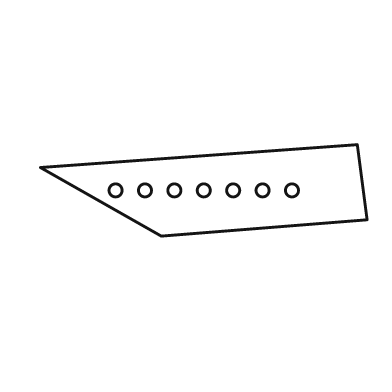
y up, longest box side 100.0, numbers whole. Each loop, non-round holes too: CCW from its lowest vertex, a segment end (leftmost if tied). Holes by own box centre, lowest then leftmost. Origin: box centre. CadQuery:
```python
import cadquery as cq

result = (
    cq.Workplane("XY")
    .moveTo(-13.0, -14.0)
    .lineTo(50.0, -9.0)
    .lineTo(47.0, 14.0)
    .lineTo(-50.0, 7.0)
    .close()
    .moveTo(-27.0, 0.0)
    .circle(2.0)
    .moveTo(-18.0, 0.0)
    .circle(2.0)
    .moveTo(-9.0, 0.0)
    .circle(2.0)
    .moveTo(0.0, 0.0)
    .circle(2.0)
    .moveTo(9.0, 0.0)
    .circle(2.0)
    .moveTo(18.0, 0.0)
    .circle(2.0)
    .moveTo(27.0, 0.0)
    .circle(2.0)
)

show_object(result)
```